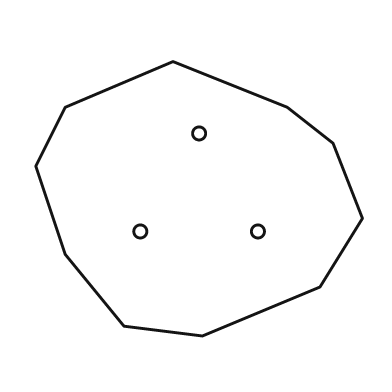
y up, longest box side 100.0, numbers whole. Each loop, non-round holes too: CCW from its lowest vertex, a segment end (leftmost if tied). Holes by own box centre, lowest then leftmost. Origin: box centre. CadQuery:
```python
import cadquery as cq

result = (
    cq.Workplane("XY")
    .moveTo(1.0, -42.0)
    .lineTo(37.0, -27.0)
    .lineTo(50.0, -6.0)
    .lineTo(41.0, 17.0)
    .lineTo(27.0, 28.0)
    .lineTo(-8.0, 42.0)
    .lineTo(-41.0, 28.0)
    .lineTo(-50.0, 10.0)
    .lineTo(-41.0, -17.0)
    .lineTo(-23.0, -39.0)
    .close()
    .moveTo(-18.0, -10.0)
    .circle(2.0)
    .moveTo(18.0, -10.0)
    .circle(2.0)
    .moveTo(0.0, 20.0)
    .circle(2.0)
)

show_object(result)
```